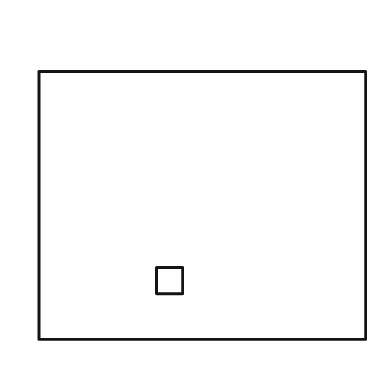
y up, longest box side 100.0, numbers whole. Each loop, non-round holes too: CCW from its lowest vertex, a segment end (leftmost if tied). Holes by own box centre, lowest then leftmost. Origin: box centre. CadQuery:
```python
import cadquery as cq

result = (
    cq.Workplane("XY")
    .moveTo(-50.0, -41.0)
    .lineTo(50.0, -41.0)
    .lineTo(50.0, 41.0)
    .lineTo(-50.0, 41.0)
    .close()
    .moveTo(-14.0, -27.0)
    .lineTo(-6.0, -27.0)
    .lineTo(-6.0, -19.0)
    .lineTo(-14.0, -19.0)
    .close()
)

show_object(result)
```